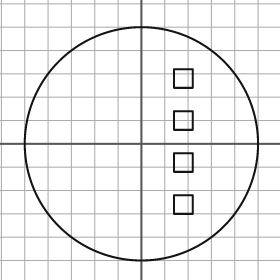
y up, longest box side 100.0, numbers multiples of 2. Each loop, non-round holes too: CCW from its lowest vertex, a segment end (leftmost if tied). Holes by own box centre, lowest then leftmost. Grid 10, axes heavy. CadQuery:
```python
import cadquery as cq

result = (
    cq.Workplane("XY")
    .moveTo(0.0, 0.0)
    .circle(50.0)
    .moveTo(14.0, -30.0)
    .lineTo(22.0, -30.0)
    .lineTo(22.0, -22.0)
    .lineTo(14.0, -22.0)
    .close()
    .moveTo(14.0, -12.0)
    .lineTo(22.0, -12.0)
    .lineTo(22.0, -4.0)
    .lineTo(14.0, -4.0)
    .close()
    .moveTo(14.0, 6.0)
    .lineTo(22.0, 6.0)
    .lineTo(22.0, 14.0)
    .lineTo(14.0, 14.0)
    .close()
    .moveTo(14.0, 24.0)
    .lineTo(22.0, 24.0)
    .lineTo(22.0, 32.0)
    .lineTo(14.0, 32.0)
    .close()
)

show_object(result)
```